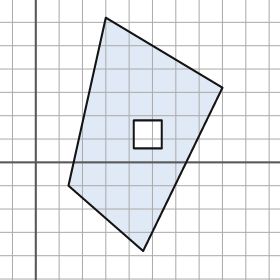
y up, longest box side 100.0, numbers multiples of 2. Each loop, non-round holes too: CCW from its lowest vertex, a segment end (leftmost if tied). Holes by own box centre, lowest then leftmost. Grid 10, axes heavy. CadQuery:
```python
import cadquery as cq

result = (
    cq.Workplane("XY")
    .moveTo(46.0, -38.0)
    .lineTo(80.0, 32.0)
    .lineTo(30.0, 62.0)
    .lineTo(14.0, -10.0)
    .close()
    .moveTo(42.0, 6.0)
    .lineTo(54.0, 6.0)
    .lineTo(54.0, 18.0)
    .lineTo(42.0, 18.0)
    .close()
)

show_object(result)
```